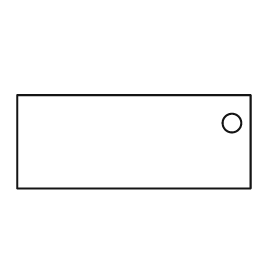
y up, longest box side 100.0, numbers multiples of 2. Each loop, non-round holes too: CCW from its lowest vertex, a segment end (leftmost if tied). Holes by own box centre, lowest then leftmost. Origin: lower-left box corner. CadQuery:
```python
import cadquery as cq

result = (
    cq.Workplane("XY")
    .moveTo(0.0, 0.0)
    .lineTo(100.0, 0.0)
    .lineTo(100.0, 40.0)
    .lineTo(0.0, 40.0)
    .close()
    .moveTo(92.0, 28.0)
    .circle(4.0)
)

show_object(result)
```